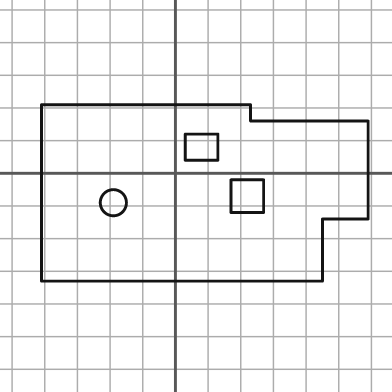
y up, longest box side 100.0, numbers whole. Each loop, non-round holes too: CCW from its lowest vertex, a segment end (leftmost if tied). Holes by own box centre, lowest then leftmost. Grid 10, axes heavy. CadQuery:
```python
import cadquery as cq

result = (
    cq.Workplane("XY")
    .moveTo(-41.0, -33.0)
    .lineTo(45.0, -33.0)
    .lineTo(45.0, -14.0)
    .lineTo(59.0, -14.0)
    .lineTo(59.0, 16.0)
    .lineTo(23.0, 16.0)
    .lineTo(23.0, 21.0)
    .lineTo(-41.0, 21.0)
    .close()
    .moveTo(-19.0, -9.0)
    .circle(4.0)
    .moveTo(17.0, -12.0)
    .lineTo(27.0, -12.0)
    .lineTo(27.0, -2.0)
    .lineTo(17.0, -2.0)
    .close()
    .moveTo(3.0, 4.0)
    .lineTo(13.0, 4.0)
    .lineTo(13.0, 12.0)
    .lineTo(3.0, 12.0)
    .close()
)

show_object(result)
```